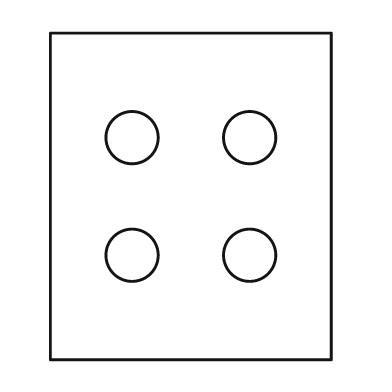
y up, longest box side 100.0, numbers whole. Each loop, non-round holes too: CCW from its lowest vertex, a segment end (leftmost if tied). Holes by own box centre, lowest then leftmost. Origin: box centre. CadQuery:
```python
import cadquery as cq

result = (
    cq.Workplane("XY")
    .moveTo(-43.0, -50.0)
    .lineTo(43.0, -50.0)
    .lineTo(43.0, 50.0)
    .lineTo(-43.0, 50.0)
    .close()
    .moveTo(-18.0, -18.0)
    .circle(8.0)
    .moveTo(18.0, -18.0)
    .circle(8.0)
    .moveTo(-18.0, 18.0)
    .circle(8.0)
    .moveTo(18.0, 18.0)
    .circle(8.0)
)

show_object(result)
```